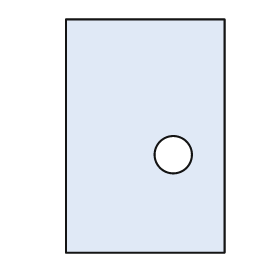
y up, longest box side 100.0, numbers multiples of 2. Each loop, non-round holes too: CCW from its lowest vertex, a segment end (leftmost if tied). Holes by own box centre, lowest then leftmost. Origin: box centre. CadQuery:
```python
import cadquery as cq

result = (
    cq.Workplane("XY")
    .moveTo(-34.0, -50.0)
    .lineTo(34.0, -50.0)
    .lineTo(34.0, 50.0)
    .lineTo(-34.0, 50.0)
    .close()
    .moveTo(12.0, -8.0)
    .circle(8.0)
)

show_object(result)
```